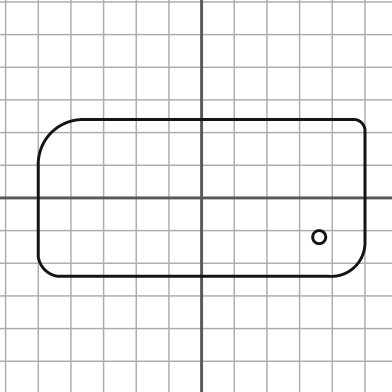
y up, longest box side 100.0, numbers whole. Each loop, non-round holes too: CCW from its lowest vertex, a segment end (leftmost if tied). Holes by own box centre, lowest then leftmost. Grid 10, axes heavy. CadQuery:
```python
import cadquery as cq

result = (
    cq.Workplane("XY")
    .moveTo(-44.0, -24.0)
    .lineTo(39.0, -24.0)
    .threePointArc((47.0, -21.0), (50.0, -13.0))
    .lineTo(50.0, 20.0)
    .threePointArc((49.0, 23.0), (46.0, 24.0))
    .lineTo(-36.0, 24.0)
    .threePointArc((-46.0, 20.0), (-50.0, 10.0))
    .lineTo(-50.0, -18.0)
    .threePointArc((-48.0, -22.0), (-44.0, -24.0))
    .close()
    .moveTo(36.0, -12.0)
    .circle(2.0)
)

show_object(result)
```